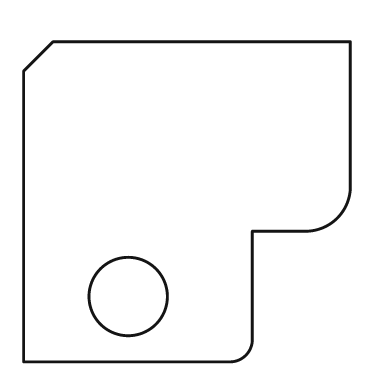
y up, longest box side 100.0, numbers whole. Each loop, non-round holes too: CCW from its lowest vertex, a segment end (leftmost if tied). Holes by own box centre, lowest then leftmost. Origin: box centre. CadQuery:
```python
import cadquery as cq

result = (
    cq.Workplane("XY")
    .moveTo(-50.0, -49.0)
    .lineTo(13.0, -49.0)
    .threePointArc((18.0, -47.0), (20.0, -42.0))
    .lineTo(20.0, -9.0)
    .lineTo(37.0, -9.0)
    .threePointArc((46.0, -5.0), (50.0, 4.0))
    .lineTo(50.0, 49.0)
    .lineTo(-41.0, 49.0)
    .lineTo(-50.0, 40.0)
    .close()
    .moveTo(-18.0, -29.0)
    .circle(12.0)
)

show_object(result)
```